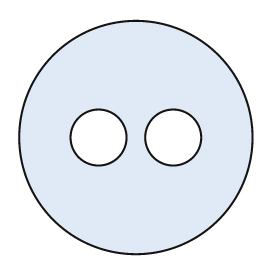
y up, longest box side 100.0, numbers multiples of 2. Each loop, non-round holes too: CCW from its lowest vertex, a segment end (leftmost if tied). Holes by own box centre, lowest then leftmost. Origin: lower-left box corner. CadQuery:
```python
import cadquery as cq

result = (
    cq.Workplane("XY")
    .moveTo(50.0, 50.0)
    .circle(50.0)
    .moveTo(34.0, 50.0)
    .circle(12.0)
    .moveTo(66.0, 50.0)
    .circle(12.0)
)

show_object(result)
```